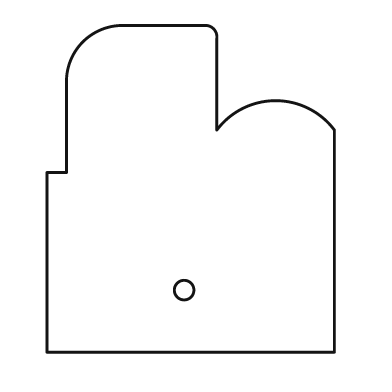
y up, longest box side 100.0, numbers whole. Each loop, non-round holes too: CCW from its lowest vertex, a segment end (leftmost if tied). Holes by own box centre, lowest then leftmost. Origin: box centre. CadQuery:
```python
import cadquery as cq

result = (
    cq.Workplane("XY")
    .moveTo(-44.0, -50.0)
    .lineTo(44.0, -50.0)
    .lineTo(44.0, 18.0)
    .threePointArc((26.0, 27.0), (8.0, 18.0))
    .lineTo(8.0, 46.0)
    .threePointArc((7.0, 49.0), (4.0, 50.0))
    .lineTo(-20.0, 50.0)
    .threePointArc((-33.0, 45.0), (-38.0, 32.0))
    .lineTo(-38.0, 5.0)
    .lineTo(-44.0, 5.0)
    .close()
    .moveTo(-2.0, -31.0)
    .circle(3.0)
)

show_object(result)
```